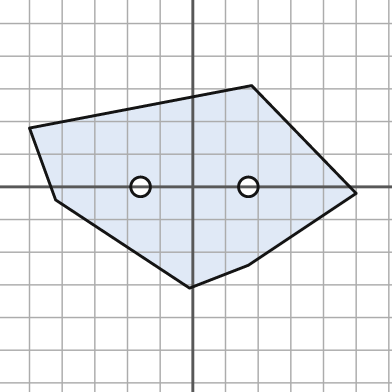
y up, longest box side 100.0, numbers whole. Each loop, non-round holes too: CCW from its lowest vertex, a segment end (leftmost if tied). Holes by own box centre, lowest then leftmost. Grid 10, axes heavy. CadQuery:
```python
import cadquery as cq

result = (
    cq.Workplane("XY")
    .moveTo(-1.0, -31.0)
    .lineTo(17.0, -24.0)
    .lineTo(50.0, -2.0)
    .lineTo(18.0, 31.0)
    .lineTo(-50.0, 18.0)
    .lineTo(-42.0, -4.0)
    .close()
    .moveTo(-16.0, 0.0)
    .circle(3.0)
    .moveTo(17.0, 0.0)
    .circle(3.0)
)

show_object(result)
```